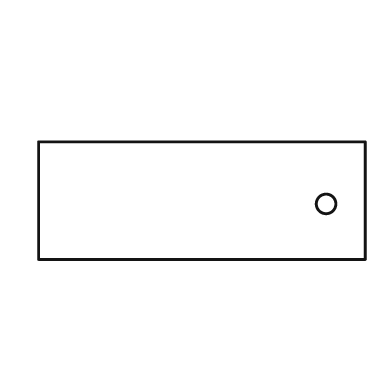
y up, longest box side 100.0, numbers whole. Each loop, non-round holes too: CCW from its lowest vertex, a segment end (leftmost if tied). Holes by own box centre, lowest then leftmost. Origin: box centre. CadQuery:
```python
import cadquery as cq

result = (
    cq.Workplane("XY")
    .moveTo(-50.0, -18.0)
    .lineTo(50.0, -18.0)
    .lineTo(50.0, 18.0)
    .lineTo(-50.0, 18.0)
    .close()
    .moveTo(38.0, -1.0)
    .circle(3.0)
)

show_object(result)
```